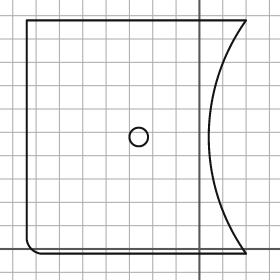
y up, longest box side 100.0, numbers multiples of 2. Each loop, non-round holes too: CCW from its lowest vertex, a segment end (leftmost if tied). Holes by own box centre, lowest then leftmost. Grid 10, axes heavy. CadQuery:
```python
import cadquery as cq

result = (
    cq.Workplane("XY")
    .moveTo(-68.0, -2.0)
    .lineTo(20.0, -2.0)
    .threePointArc((4.0, 48.0), (20.0, 98.0))
    .lineTo(-74.0, 98.0)
    .lineTo(-74.0, 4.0)
    .threePointArc((-72.0, 0.0), (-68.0, -2.0))
    .close()
    .moveTo(-26.0, 48.0)
    .circle(4.0)
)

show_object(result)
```